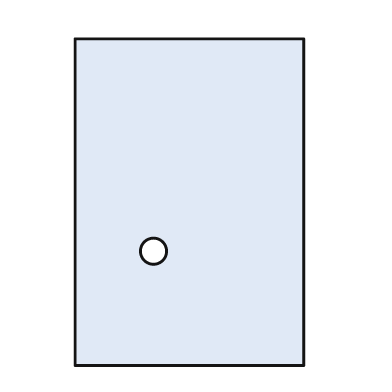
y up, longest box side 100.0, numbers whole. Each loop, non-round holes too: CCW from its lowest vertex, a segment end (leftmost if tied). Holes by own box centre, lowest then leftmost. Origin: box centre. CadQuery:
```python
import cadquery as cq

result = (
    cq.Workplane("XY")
    .moveTo(-35.0, -50.0)
    .lineTo(35.0, -50.0)
    .lineTo(35.0, 50.0)
    .lineTo(-35.0, 50.0)
    .close()
    .moveTo(-11.0, -15.0)
    .circle(4.0)
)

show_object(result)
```